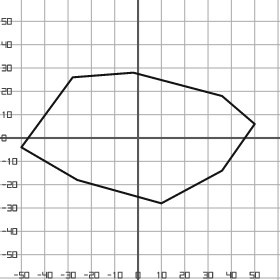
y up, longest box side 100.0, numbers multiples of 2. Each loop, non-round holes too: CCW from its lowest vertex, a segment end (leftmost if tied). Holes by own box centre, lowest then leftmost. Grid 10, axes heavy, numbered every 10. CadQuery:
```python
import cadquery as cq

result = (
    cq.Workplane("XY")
    .moveTo(10.0, -28.0)
    .lineTo(36.0, -14.0)
    .lineTo(50.0, 6.0)
    .lineTo(36.0, 18.0)
    .lineTo(-2.0, 28.0)
    .lineTo(-28.0, 26.0)
    .lineTo(-50.0, -4.0)
    .lineTo(-26.0, -18.0)
    .close()
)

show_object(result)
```